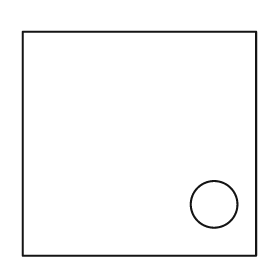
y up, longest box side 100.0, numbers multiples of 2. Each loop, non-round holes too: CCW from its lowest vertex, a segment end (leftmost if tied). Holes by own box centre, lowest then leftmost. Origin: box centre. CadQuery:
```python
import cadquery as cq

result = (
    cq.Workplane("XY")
    .moveTo(-50.0, -48.0)
    .lineTo(50.0, -48.0)
    .lineTo(50.0, 48.0)
    .lineTo(-50.0, 48.0)
    .close()
    .moveTo(32.0, -26.0)
    .circle(10.0)
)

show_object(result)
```